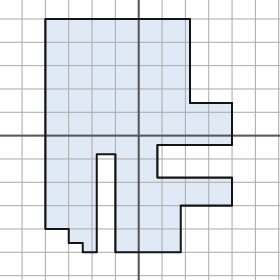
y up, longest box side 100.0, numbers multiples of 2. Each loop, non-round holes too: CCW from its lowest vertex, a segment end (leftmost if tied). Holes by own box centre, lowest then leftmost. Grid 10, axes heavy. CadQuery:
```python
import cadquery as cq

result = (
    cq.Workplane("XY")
    .moveTo(-24.0, -50.0)
    .lineTo(-18.0, -50.0)
    .lineTo(-18.0, -8.0)
    .lineTo(-10.0, -8.0)
    .lineTo(-10.0, -50.0)
    .lineTo(18.0, -50.0)
    .lineTo(18.0, -30.0)
    .lineTo(40.0, -30.0)
    .lineTo(40.0, -18.0)
    .lineTo(8.0, -18.0)
    .lineTo(8.0, -4.0)
    .lineTo(40.0, -4.0)
    .lineTo(40.0, 14.0)
    .lineTo(22.0, 14.0)
    .lineTo(22.0, 50.0)
    .lineTo(-40.0, 50.0)
    .lineTo(-40.0, -40.0)
    .lineTo(-30.0, -40.0)
    .lineTo(-30.0, -46.0)
    .lineTo(-24.0, -46.0)
    .close()
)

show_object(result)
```